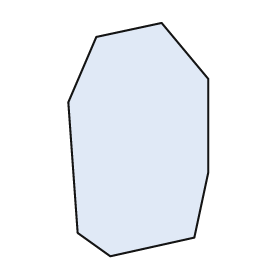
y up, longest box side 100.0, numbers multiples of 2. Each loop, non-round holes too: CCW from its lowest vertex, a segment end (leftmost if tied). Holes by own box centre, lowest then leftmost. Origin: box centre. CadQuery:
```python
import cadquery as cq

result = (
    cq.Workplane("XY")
    .moveTo(-12.0, -50.0)
    .lineTo(24.0, -42.0)
    .lineTo(30.0, -14.0)
    .lineTo(30.0, 26.0)
    .lineTo(10.0, 50.0)
    .lineTo(-18.0, 44.0)
    .lineTo(-30.0, 16.0)
    .lineTo(-26.0, -40.0)
    .close()
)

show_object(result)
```